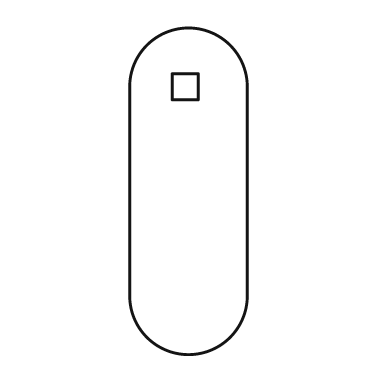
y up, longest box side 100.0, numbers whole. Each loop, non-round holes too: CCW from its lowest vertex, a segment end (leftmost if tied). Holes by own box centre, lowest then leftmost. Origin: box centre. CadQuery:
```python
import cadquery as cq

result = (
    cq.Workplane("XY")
    .moveTo(-18.0, -32.0)
    .threePointArc((0.0, -50.0), (18.0, -32.0))
    .lineTo(18.0, 32.0)
    .threePointArc((0.0, 50.0), (-18.0, 32.0))
    .close()
    .moveTo(-5.0, 28.0)
    .lineTo(3.0, 28.0)
    .lineTo(3.0, 36.0)
    .lineTo(-5.0, 36.0)
    .close()
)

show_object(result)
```